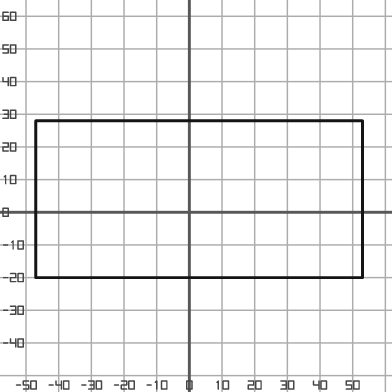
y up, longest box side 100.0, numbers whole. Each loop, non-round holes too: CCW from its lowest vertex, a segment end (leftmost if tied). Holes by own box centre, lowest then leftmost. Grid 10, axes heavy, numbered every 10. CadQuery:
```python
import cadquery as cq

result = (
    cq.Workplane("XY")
    .moveTo(-47.0, -20.0)
    .lineTo(53.0, -20.0)
    .lineTo(53.0, 28.0)
    .lineTo(-47.0, 28.0)
    .close()
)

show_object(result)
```